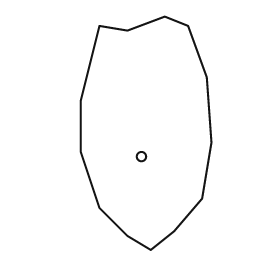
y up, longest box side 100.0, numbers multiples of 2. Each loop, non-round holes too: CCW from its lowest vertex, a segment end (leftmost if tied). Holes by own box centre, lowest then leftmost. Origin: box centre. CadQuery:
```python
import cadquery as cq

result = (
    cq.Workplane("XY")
    .moveTo(2.0, -50.0)
    .lineTo(12.0, -42.0)
    .lineTo(24.0, -28.0)
    .lineTo(28.0, -4.0)
    .lineTo(26.0, 24.0)
    .lineTo(18.0, 46.0)
    .lineTo(8.0, 50.0)
    .lineTo(-8.0, 44.0)
    .lineTo(-20.0, 46.0)
    .lineTo(-28.0, 14.0)
    .lineTo(-28.0, -8.0)
    .lineTo(-20.0, -32.0)
    .lineTo(-8.0, -44.0)
    .close()
    .moveTo(-2.0, -10.0)
    .circle(2.0)
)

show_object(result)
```